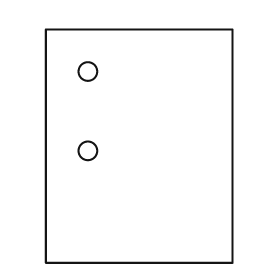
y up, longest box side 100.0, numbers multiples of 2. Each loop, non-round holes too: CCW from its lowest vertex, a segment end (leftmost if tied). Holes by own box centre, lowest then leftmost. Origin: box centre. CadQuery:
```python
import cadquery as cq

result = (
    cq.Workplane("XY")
    .moveTo(-40.0, -50.0)
    .lineTo(40.0, -50.0)
    .lineTo(40.0, 50.0)
    .lineTo(-40.0, 50.0)
    .close()
    .moveTo(-22.0, -2.0)
    .circle(4.0)
    .moveTo(-22.0, 32.0)
    .circle(4.0)
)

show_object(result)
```